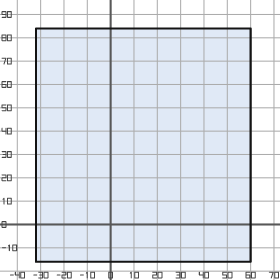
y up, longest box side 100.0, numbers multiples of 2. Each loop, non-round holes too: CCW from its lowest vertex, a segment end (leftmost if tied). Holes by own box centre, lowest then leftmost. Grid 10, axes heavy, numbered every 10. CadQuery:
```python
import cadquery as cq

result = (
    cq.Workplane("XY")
    .moveTo(-32.0, -16.0)
    .lineTo(60.0, -16.0)
    .lineTo(60.0, 84.0)
    .lineTo(-32.0, 84.0)
    .close()
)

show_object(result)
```